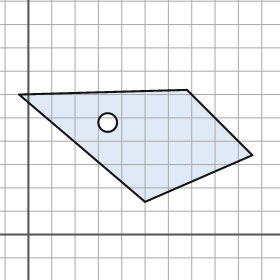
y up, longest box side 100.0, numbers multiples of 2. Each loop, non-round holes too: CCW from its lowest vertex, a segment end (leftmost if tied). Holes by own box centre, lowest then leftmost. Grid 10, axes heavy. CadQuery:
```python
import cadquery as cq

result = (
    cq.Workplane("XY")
    .moveTo(50.0, 14.0)
    .lineTo(96.0, 34.0)
    .lineTo(68.0, 62.0)
    .lineTo(-4.0, 60.0)
    .close()
    .moveTo(34.0, 48.0)
    .circle(4.0)
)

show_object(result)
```